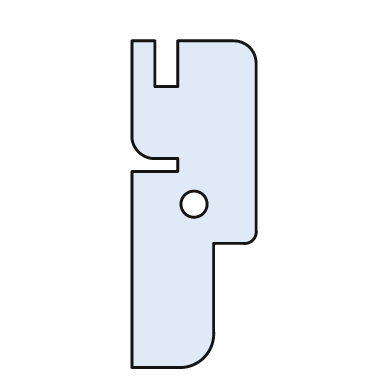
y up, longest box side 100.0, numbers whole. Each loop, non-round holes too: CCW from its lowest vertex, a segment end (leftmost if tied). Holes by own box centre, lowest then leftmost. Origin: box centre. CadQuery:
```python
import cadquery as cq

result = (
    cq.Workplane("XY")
    .moveTo(-19.0, -50.0)
    .lineTo(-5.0, -50.0)
    .threePointArc((3.0, -47.0), (6.0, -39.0))
    .lineTo(6.0, -12.0)
    .lineTo(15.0, -12.0)
    .threePointArc((18.0, -11.0), (19.0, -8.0))
    .lineTo(19.0, 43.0)
    .threePointArc((17.0, 48.0), (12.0, 50.0))
    .lineTo(-5.0, 50.0)
    .lineTo(-5.0, 36.0)
    .lineTo(-12.0, 36.0)
    .lineTo(-12.0, 50.0)
    .lineTo(-19.0, 50.0)
    .lineTo(-19.0, 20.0)
    .threePointArc((-17.0, 16.0), (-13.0, 14.0))
    .lineTo(-5.0, 14.0)
    .lineTo(-5.0, 10.0)
    .lineTo(-19.0, 10.0)
    .close()
    .moveTo(0.0, 0.0)
    .circle(4.0)
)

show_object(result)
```